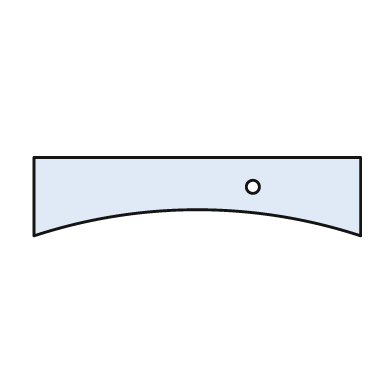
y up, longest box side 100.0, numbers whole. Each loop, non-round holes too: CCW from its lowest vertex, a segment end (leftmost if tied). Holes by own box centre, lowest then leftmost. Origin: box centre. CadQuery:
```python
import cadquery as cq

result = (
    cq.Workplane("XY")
    .moveTo(-50.0, -12.0)
    .threePointArc((0.0, -4.0), (50.0, -12.0))
    .lineTo(50.0, 12.0)
    .lineTo(-50.0, 12.0)
    .close()
    .moveTo(17.0, 3.0)
    .circle(2.0)
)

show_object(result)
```